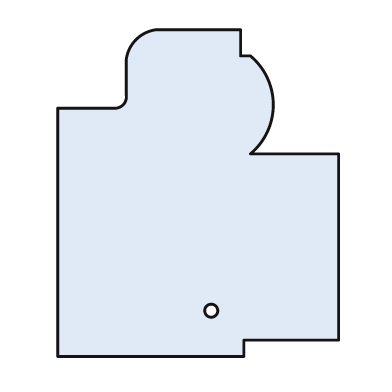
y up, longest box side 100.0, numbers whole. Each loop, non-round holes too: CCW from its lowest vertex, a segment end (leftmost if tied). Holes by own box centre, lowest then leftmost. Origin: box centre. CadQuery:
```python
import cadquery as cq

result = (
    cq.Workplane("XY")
    .moveTo(-43.0, -50.0)
    .lineTo(14.0, -50.0)
    .lineTo(14.0, -45.0)
    .lineTo(43.0, -45.0)
    .lineTo(43.0, 12.0)
    .lineTo(16.0, 12.0)
    .threePointArc((23.0, 27.0), (16.0, 42.0))
    .lineTo(13.0, 42.0)
    .lineTo(13.0, 50.0)
    .lineTo(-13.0, 50.0)
    .threePointArc((-19.0, 47.0), (-22.0, 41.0))
    .lineTo(-22.0, 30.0)
    .threePointArc((-23.0, 27.0), (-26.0, 26.0))
    .lineTo(-43.0, 26.0)
    .close()
    .moveTo(4.0, -36.0)
    .circle(2.0)
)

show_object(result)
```